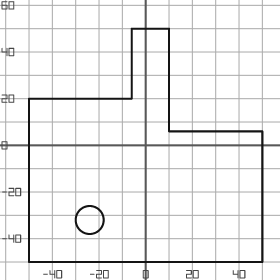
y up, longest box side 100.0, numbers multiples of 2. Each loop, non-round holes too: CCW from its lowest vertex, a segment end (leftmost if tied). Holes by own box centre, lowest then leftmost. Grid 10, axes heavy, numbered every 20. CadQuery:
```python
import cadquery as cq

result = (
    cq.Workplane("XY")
    .moveTo(-50.0, -50.0)
    .lineTo(50.0, -50.0)
    .lineTo(50.0, 6.0)
    .lineTo(10.0, 6.0)
    .lineTo(10.0, 50.0)
    .lineTo(-6.0, 50.0)
    .lineTo(-6.0, 20.0)
    .lineTo(-50.0, 20.0)
    .close()
    .moveTo(-24.0, -32.0)
    .circle(6.0)
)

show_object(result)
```